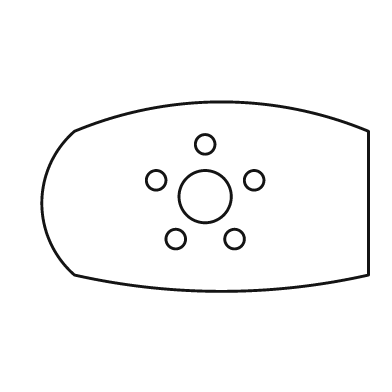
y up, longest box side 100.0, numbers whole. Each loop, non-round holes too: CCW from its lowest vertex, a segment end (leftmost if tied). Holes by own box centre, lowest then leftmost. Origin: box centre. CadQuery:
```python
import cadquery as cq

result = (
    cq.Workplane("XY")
    .moveTo(-40.0, -24.0)
    .threePointArc((5.0, -29.0), (50.0, -24.0))
    .lineTo(50.0, 20.0)
    .threePointArc((5.0, 29.0), (-40.0, 20.0))
    .threePointArc((-50.0, -2.0), (-40.0, -24.0))
    .close()
    .moveTo(-9.0, -13.0)
    .circle(3.0)
    .moveTo(9.0, -13.0)
    .circle(3.0)
    .moveTo(0.0, 0.0)
    .circle(8.0)
    .moveTo(-15.0, 5.0)
    .circle(3.0)
    .moveTo(15.0, 5.0)
    .circle(3.0)
    .moveTo(0.0, 16.0)
    .circle(3.0)
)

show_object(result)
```